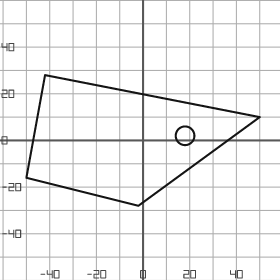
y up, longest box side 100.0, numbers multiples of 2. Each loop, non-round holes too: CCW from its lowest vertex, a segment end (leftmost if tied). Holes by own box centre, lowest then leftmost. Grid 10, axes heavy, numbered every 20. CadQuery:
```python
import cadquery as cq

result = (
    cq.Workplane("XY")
    .moveTo(-2.0, -28.0)
    .lineTo(50.0, 10.0)
    .lineTo(-42.0, 28.0)
    .lineTo(-50.0, -16.0)
    .close()
    .moveTo(18.0, 2.0)
    .circle(4.0)
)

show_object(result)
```